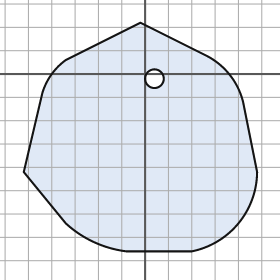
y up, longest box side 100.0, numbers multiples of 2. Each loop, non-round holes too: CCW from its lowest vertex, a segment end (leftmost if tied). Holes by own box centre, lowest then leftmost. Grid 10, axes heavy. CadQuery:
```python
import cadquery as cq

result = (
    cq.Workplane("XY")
    .moveTo(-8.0, -76.0)
    .lineTo(20.0, -76.0)
    .threePointArc((40.0, -64.0), (48.0, -42.0))
    .lineTo(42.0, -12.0)
    .threePointArc((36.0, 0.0), (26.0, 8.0))
    .lineTo(-2.0, 22.0)
    .lineTo(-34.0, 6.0)
    .threePointArc((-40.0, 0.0), (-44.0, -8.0))
    .lineTo(-52.0, -42.0)
    .lineTo(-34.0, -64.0)
    .threePointArc((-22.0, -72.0), (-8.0, -76.0))
    .close()
    .moveTo(4.0, -2.0)
    .circle(4.0)
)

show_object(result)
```